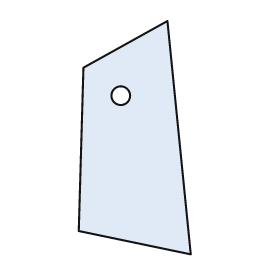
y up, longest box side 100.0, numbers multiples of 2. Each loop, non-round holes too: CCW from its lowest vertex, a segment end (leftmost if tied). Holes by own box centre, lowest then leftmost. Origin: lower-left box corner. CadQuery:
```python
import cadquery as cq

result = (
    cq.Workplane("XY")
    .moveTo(48.0, 0.0)
    .lineTo(38.0, 100.0)
    .lineTo(2.0, 80.0)
    .lineTo(0.0, 10.0)
    .close()
    .moveTo(18.0, 68.0)
    .circle(4.0)
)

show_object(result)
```